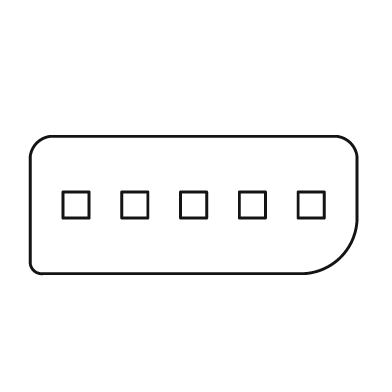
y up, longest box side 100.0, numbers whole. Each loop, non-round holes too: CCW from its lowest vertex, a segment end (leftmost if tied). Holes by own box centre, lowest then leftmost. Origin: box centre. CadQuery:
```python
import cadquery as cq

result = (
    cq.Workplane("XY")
    .moveTo(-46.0, -21.0)
    .lineTo(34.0, -21.0)
    .threePointArc((45.0, -16.0), (50.0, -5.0))
    .lineTo(50.0, 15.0)
    .threePointArc((48.0, 19.0), (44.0, 21.0))
    .lineTo(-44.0, 21.0)
    .threePointArc((-48.0, 19.0), (-50.0, 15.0))
    .lineTo(-50.0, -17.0)
    .threePointArc((-49.0, -20.0), (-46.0, -21.0))
    .close()
    .moveTo(-40.0, -4.0)
    .lineTo(-32.0, -4.0)
    .lineTo(-32.0, 4.0)
    .lineTo(-40.0, 4.0)
    .close()
    .moveTo(-22.0, -4.0)
    .lineTo(-14.0, -4.0)
    .lineTo(-14.0, 4.0)
    .lineTo(-22.0, 4.0)
    .close()
    .moveTo(-4.0, -4.0)
    .lineTo(4.0, -4.0)
    .lineTo(4.0, 4.0)
    .lineTo(-4.0, 4.0)
    .close()
    .moveTo(14.0, -4.0)
    .lineTo(22.0, -4.0)
    .lineTo(22.0, 4.0)
    .lineTo(14.0, 4.0)
    .close()
    .moveTo(32.0, -4.0)
    .lineTo(40.0, -4.0)
    .lineTo(40.0, 4.0)
    .lineTo(32.0, 4.0)
    .close()
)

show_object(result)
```